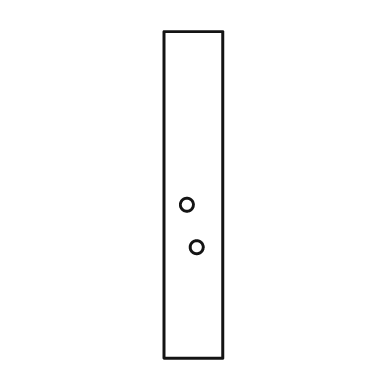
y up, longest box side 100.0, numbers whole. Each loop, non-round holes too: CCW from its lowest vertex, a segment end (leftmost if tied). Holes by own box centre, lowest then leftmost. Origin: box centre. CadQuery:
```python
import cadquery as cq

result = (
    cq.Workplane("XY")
    .moveTo(-9.0, -50.0)
    .lineTo(9.0, -50.0)
    .lineTo(9.0, 50.0)
    .lineTo(-9.0, 50.0)
    .close()
    .moveTo(1.0, -16.0)
    .circle(2.0)
    .moveTo(-2.0, -3.0)
    .circle(2.0)
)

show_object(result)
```